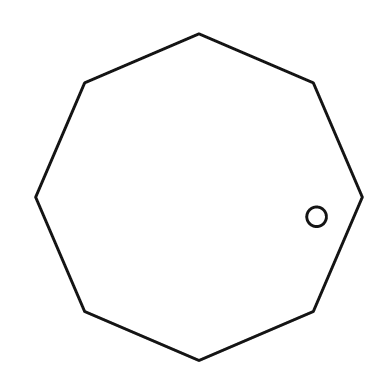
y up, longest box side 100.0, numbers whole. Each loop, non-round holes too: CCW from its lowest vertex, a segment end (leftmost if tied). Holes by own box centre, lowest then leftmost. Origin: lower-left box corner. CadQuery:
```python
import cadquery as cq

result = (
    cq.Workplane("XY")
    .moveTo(50.0, 0.0)
    .lineTo(85.0, 15.0)
    .lineTo(100.0, 50.0)
    .lineTo(85.0, 85.0)
    .lineTo(50.0, 100.0)
    .lineTo(15.0, 85.0)
    .lineTo(0.0, 50.0)
    .lineTo(15.0, 15.0)
    .close()
    .moveTo(86.0, 44.0)
    .circle(3.0)
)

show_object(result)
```